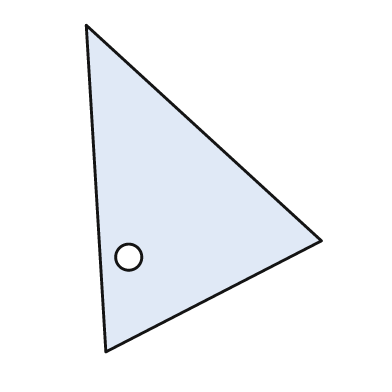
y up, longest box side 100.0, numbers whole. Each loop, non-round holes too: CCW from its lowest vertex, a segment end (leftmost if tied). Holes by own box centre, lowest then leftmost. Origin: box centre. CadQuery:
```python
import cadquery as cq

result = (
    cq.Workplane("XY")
    .moveTo(-30.0, -50.0)
    .lineTo(36.0, -16.0)
    .lineTo(-36.0, 50.0)
    .close()
    .moveTo(-23.0, -21.0)
    .circle(4.0)
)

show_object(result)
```